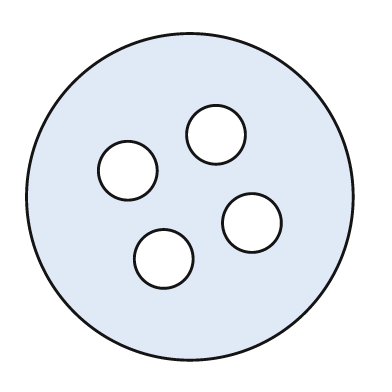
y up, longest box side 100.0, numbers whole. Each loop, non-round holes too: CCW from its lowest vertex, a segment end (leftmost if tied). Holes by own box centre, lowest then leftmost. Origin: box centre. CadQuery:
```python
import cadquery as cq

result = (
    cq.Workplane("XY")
    .moveTo(0.0, 0.0)
    .circle(50.0)
    .moveTo(-8.0, -19.0)
    .circle(9.0)
    .moveTo(19.0, -8.0)
    .circle(9.0)
    .moveTo(-19.0, 8.0)
    .circle(9.0)
    .moveTo(8.0, 19.0)
    .circle(9.0)
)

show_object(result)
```